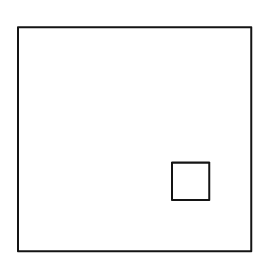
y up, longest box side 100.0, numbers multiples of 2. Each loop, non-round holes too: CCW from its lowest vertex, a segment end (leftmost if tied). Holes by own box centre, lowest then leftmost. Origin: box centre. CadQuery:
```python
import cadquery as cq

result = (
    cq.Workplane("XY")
    .moveTo(-50.0, -48.0)
    .lineTo(50.0, -48.0)
    .lineTo(50.0, 48.0)
    .lineTo(-50.0, 48.0)
    .close()
    .moveTo(16.0, -26.0)
    .lineTo(32.0, -26.0)
    .lineTo(32.0, -10.0)
    .lineTo(16.0, -10.0)
    .close()
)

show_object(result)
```